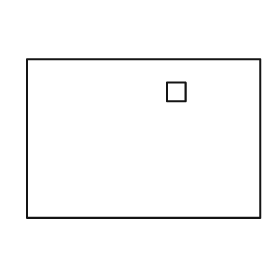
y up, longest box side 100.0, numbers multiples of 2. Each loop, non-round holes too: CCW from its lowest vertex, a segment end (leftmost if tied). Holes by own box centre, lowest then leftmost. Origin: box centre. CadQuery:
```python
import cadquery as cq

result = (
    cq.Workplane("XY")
    .moveTo(-50.0, -34.0)
    .lineTo(50.0, -34.0)
    .lineTo(50.0, 34.0)
    .lineTo(-50.0, 34.0)
    .close()
    .moveTo(10.0, 16.0)
    .lineTo(18.0, 16.0)
    .lineTo(18.0, 24.0)
    .lineTo(10.0, 24.0)
    .close()
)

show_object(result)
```